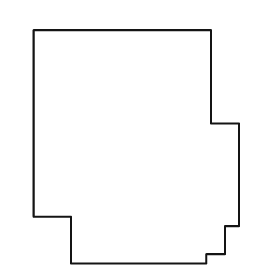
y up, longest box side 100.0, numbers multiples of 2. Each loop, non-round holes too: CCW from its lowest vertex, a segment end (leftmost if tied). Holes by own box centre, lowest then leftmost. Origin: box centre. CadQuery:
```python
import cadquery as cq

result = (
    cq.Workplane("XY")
    .moveTo(-28.0, -50.0)
    .lineTo(30.0, -50.0)
    .lineTo(30.0, -46.0)
    .lineTo(38.0, -46.0)
    .lineTo(38.0, -34.0)
    .lineTo(44.0, -34.0)
    .lineTo(44.0, 10.0)
    .lineTo(32.0, 10.0)
    .lineTo(32.0, 50.0)
    .lineTo(-44.0, 50.0)
    .lineTo(-44.0, -30.0)
    .lineTo(-28.0, -30.0)
    .close()
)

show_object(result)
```